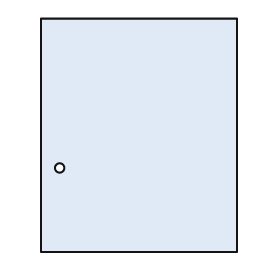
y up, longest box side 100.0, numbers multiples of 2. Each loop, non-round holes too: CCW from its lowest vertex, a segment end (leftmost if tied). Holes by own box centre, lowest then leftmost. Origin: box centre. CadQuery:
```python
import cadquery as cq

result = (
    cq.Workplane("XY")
    .moveTo(-42.0, -50.0)
    .lineTo(42.0, -50.0)
    .lineTo(42.0, 50.0)
    .lineTo(-42.0, 50.0)
    .close()
    .moveTo(-34.0, -14.0)
    .circle(2.0)
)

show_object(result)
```